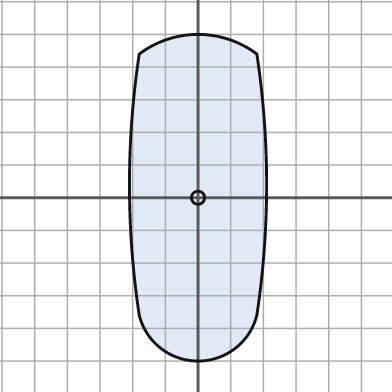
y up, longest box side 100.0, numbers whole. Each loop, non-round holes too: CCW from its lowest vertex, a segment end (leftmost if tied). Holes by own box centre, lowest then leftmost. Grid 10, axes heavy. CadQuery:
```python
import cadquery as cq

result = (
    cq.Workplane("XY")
    .moveTo(-18.0, -36.0)
    .threePointArc((0.0, -50.0), (18.0, -36.0))
    .threePointArc((21.0, 4.0), (18.0, 44.0))
    .threePointArc((0.0, 50.0), (-18.0, 44.0))
    .threePointArc((-21.0, 4.0), (-18.0, -36.0))
    .close()
    .moveTo(0.0, 0.0)
    .circle(2.0)
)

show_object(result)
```